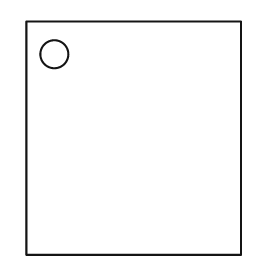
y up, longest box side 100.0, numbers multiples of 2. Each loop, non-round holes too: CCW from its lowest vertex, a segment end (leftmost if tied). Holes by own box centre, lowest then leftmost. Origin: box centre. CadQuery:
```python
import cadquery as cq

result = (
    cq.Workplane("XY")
    .moveTo(-46.0, -50.0)
    .lineTo(46.0, -50.0)
    .lineTo(46.0, 50.0)
    .lineTo(-46.0, 50.0)
    .close()
    .moveTo(-34.0, 36.0)
    .circle(6.0)
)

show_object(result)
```